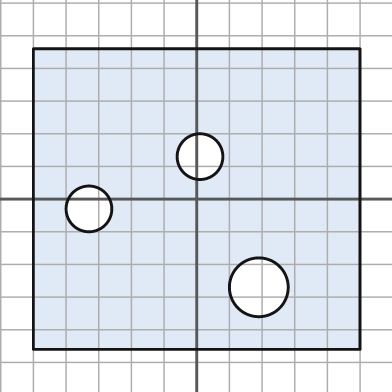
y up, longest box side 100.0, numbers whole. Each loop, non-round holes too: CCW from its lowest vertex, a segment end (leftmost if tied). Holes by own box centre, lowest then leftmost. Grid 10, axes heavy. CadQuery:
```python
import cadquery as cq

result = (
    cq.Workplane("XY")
    .moveTo(-50.0, -46.0)
    .lineTo(50.0, -46.0)
    .lineTo(50.0, 46.0)
    .lineTo(-50.0, 46.0)
    .close()
    .moveTo(19.0, -27.0)
    .circle(9.0)
    .moveTo(-33.0, -3.0)
    .circle(7.0)
    .moveTo(1.0, 13.0)
    .circle(7.0)
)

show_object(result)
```